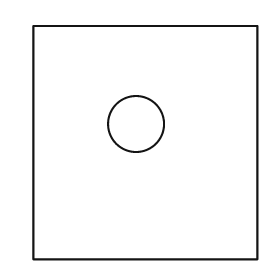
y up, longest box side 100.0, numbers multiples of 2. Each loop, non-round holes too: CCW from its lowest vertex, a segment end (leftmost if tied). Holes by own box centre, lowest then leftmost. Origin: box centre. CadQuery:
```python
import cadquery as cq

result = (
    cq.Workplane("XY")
    .moveTo(-48.0, -50.0)
    .lineTo(48.0, -50.0)
    .lineTo(48.0, 50.0)
    .lineTo(-48.0, 50.0)
    .close()
    .moveTo(-4.0, 8.0)
    .circle(12.0)
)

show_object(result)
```